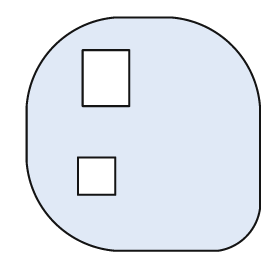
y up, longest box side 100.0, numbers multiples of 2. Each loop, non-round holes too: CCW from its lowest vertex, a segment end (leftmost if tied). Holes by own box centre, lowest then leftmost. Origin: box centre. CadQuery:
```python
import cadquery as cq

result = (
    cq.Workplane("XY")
    .moveTo(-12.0, -50.0)
    .lineTo(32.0, -50.0)
    .threePointArc((44.0, -44.0), (50.0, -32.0))
    .lineTo(50.0, 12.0)
    .threePointArc((38.0, 38.0), (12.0, 50.0))
    .lineTo(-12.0, 50.0)
    .threePointArc((-38.0, 38.0), (-50.0, 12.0))
    .lineTo(-50.0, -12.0)
    .threePointArc((-38.0, -38.0), (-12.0, -50.0))
    .close()
    .moveTo(-28.0, -26.0)
    .lineTo(-12.0, -26.0)
    .lineTo(-12.0, -10.0)
    .lineTo(-28.0, -10.0)
    .close()
    .moveTo(-26.0, 12.0)
    .lineTo(-6.0, 12.0)
    .lineTo(-6.0, 36.0)
    .lineTo(-26.0, 36.0)
    .close()
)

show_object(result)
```